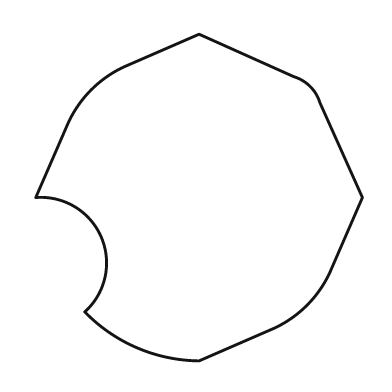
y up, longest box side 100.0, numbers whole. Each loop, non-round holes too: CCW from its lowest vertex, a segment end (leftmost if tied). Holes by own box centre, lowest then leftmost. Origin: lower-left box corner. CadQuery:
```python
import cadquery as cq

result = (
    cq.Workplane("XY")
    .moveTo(50.0, 0.0)
    .lineTo(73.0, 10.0)
    .threePointArc((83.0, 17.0), (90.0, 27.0))
    .lineTo(100.0, 50.0)
    .lineTo(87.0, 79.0)
    .threePointArc((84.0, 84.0), (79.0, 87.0))
    .lineTo(50.0, 100.0)
    .lineTo(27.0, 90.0)
    .threePointArc((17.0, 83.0), (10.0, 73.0))
    .lineTo(0.0, 50.0)
    .threePointArc((20.0, 38.0), (15.0, 15.0))
    .threePointArc((31.0, 4.0), (50.0, 0.0))
    .close()
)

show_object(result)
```